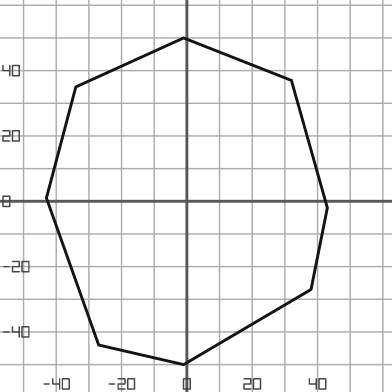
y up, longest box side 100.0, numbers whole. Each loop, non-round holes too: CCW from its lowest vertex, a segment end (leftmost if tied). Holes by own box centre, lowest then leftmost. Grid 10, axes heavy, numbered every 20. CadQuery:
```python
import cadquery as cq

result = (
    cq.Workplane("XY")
    .moveTo(-1.0, -50.0)
    .lineTo(38.0, -27.0)
    .lineTo(43.0, -2.0)
    .lineTo(32.0, 37.0)
    .lineTo(-1.0, 50.0)
    .lineTo(-34.0, 35.0)
    .lineTo(-43.0, 1.0)
    .lineTo(-27.0, -44.0)
    .close()
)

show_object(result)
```